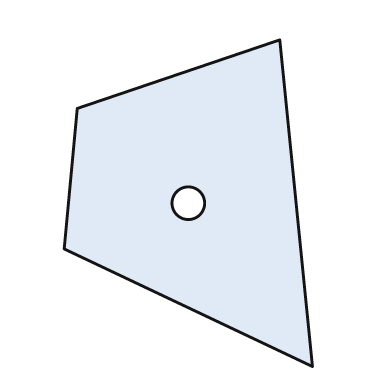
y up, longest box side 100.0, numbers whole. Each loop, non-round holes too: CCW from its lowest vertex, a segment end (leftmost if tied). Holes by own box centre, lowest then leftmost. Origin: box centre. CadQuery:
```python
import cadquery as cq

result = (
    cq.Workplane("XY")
    .moveTo(38.0, -50.0)
    .lineTo(28.0, 50.0)
    .lineTo(-34.0, 29.0)
    .lineTo(-38.0, -14.0)
    .close()
    .moveTo(0.0, 0.0)
    .circle(5.0)
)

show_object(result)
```